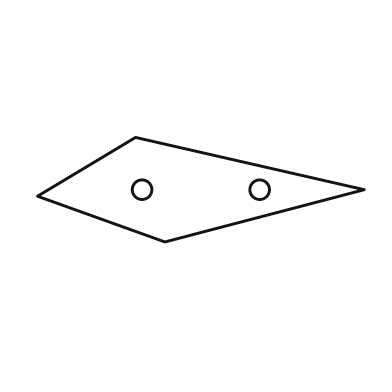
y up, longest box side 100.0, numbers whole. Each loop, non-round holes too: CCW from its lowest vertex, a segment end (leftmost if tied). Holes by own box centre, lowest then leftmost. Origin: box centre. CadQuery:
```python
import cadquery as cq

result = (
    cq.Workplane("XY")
    .moveTo(-11.0, -16.0)
    .lineTo(50.0, 0.0)
    .lineTo(-20.0, 16.0)
    .lineTo(-50.0, -2.0)
    .close()
    .moveTo(-18.0, 0.0)
    .circle(3.0)
    .moveTo(18.0, 0.0)
    .circle(3.0)
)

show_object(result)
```